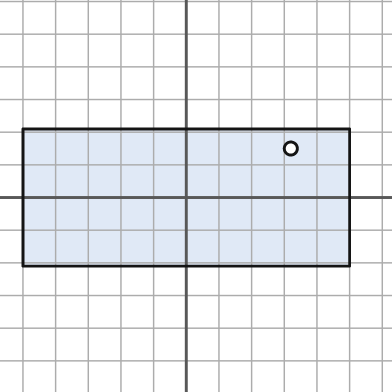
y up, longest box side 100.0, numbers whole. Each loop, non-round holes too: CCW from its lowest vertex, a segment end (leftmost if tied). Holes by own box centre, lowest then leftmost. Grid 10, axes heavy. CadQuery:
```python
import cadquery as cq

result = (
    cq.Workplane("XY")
    .moveTo(-50.0, -21.0)
    .lineTo(50.0, -21.0)
    .lineTo(50.0, 21.0)
    .lineTo(-50.0, 21.0)
    .close()
    .moveTo(32.0, 15.0)
    .circle(2.0)
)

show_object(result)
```